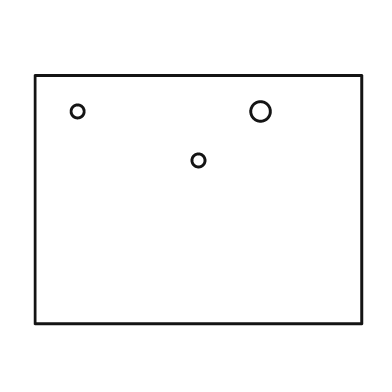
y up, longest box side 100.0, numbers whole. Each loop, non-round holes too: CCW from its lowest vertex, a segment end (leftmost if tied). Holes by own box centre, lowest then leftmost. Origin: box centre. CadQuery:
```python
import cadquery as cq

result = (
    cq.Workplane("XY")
    .moveTo(-50.0, -38.0)
    .lineTo(50.0, -38.0)
    .lineTo(50.0, 38.0)
    .lineTo(-50.0, 38.0)
    .close()
    .moveTo(0.0, 12.0)
    .circle(2.0)
    .moveTo(-37.0, 27.0)
    .circle(2.0)
    .moveTo(19.0, 27.0)
    .circle(3.0)
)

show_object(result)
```